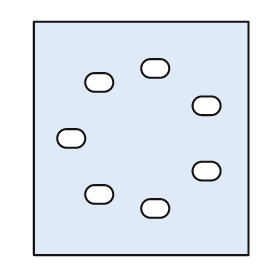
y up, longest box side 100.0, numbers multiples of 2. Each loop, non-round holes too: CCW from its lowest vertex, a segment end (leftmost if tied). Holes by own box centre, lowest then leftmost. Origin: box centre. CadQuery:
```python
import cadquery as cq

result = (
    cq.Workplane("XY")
    .moveTo(-46.0, -50.0)
    .lineTo(46.0, -50.0)
    .lineTo(46.0, 50.0)
    .lineTo(-46.0, 50.0)
    .close()
    .moveTo(4.0, -34.0)
    .lineTo(8.0, -34.0)
    .threePointArc((12.0, -30.0), (8.0, -26.0))
    .lineTo(4.0, -26.0)
    .threePointArc((0.0, -30.0), (4.0, -34.0))
    .close()
    .moveTo(-20.0, -28.0)
    .lineTo(-16.0, -28.0)
    .threePointArc((-12.0, -24.0), (-16.0, -20.0))
    .lineTo(-20.0, -20.0)
    .threePointArc((-24.0, -24.0), (-20.0, -28.0))
    .close()
    .moveTo(26.0, -18.0)
    .lineTo(30.0, -18.0)
    .threePointArc((34.0, -14.0), (30.0, -10.0))
    .lineTo(26.0, -10.0)
    .threePointArc((22.0, -14.0), (26.0, -18.0))
    .close()
    .moveTo(-32.0, -4.0)
    .lineTo(-28.0, -4.0)
    .threePointArc((-24.0, 0.0), (-28.0, 4.0))
    .lineTo(-32.0, 4.0)
    .threePointArc((-36.0, 0.0), (-32.0, -4.0))
    .close()
    .moveTo(26.0, 10.0)
    .lineTo(30.0, 10.0)
    .threePointArc((34.0, 14.0), (30.0, 18.0))
    .lineTo(26.0, 18.0)
    .threePointArc((22.0, 14.0), (26.0, 10.0))
    .close()
    .moveTo(-20.0, 20.0)
    .lineTo(-16.0, 20.0)
    .threePointArc((-12.0, 24.0), (-16.0, 28.0))
    .lineTo(-20.0, 28.0)
    .threePointArc((-24.0, 24.0), (-20.0, 20.0))
    .close()
    .moveTo(4.0, 26.0)
    .lineTo(8.0, 26.0)
    .threePointArc((12.0, 30.0), (8.0, 34.0))
    .lineTo(4.0, 34.0)
    .threePointArc((0.0, 30.0), (4.0, 26.0))
    .close()
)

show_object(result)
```